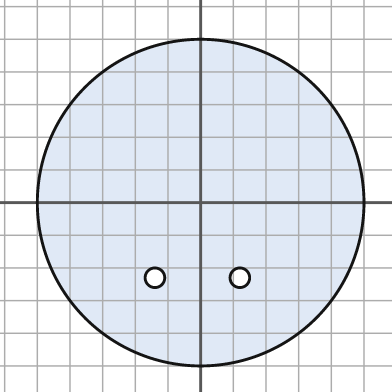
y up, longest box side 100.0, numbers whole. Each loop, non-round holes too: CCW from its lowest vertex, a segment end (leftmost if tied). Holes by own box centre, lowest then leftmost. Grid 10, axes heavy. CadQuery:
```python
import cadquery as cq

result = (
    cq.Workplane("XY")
    .moveTo(0.0, 0.0)
    .circle(50.0)
    .moveTo(-14.0, -23.0)
    .circle(3.0)
    .moveTo(12.0, -23.0)
    .circle(3.0)
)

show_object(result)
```